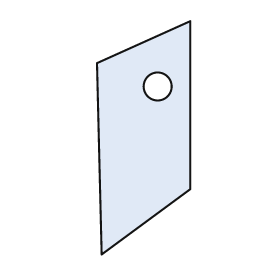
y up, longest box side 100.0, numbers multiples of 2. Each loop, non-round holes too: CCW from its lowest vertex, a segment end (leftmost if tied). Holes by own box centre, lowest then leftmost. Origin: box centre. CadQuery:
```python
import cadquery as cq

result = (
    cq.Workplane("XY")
    .moveTo(-18.0, -50.0)
    .lineTo(20.0, -22.0)
    .lineTo(20.0, 50.0)
    .lineTo(-20.0, 32.0)
    .close()
    .moveTo(6.0, 22.0)
    .circle(6.0)
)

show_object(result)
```